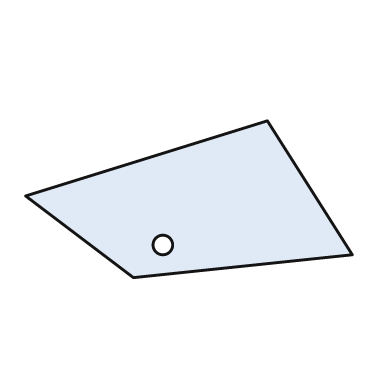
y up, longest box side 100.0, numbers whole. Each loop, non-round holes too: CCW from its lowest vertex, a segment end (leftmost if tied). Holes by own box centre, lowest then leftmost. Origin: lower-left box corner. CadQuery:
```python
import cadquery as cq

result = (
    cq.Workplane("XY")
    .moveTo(33.0, 0.0)
    .lineTo(100.0, 7.0)
    .lineTo(74.0, 48.0)
    .lineTo(0.0, 25.0)
    .close()
    .moveTo(42.0, 10.0)
    .circle(3.0)
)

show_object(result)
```